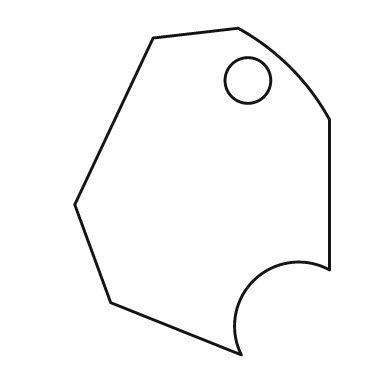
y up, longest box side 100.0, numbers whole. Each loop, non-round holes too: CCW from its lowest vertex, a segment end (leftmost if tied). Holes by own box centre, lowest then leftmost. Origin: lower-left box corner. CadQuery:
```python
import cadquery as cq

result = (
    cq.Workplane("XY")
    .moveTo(51.0, 0.0)
    .threePointArc((55.0, 23.0), (78.0, 26.0))
    .lineTo(78.0, 72.0)
    .threePointArc((66.0, 88.0), (50.0, 100.0))
    .lineTo(24.0, 97.0)
    .lineTo(0.0, 46.0)
    .lineTo(11.0, 16.0)
    .close()
    .moveTo(53.0, 84.0)
    .circle(7.0)
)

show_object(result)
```